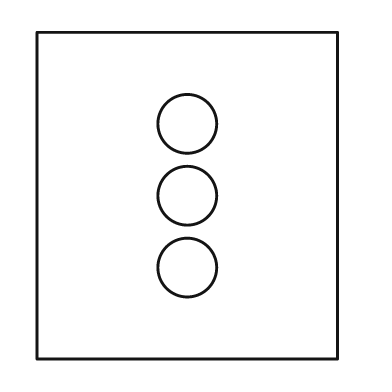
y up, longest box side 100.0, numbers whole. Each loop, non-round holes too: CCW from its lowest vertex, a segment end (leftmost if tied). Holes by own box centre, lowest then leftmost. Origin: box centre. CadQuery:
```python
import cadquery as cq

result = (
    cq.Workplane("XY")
    .moveTo(-46.0, -50.0)
    .lineTo(46.0, -50.0)
    .lineTo(46.0, 50.0)
    .lineTo(-46.0, 50.0)
    .close()
    .moveTo(0.0, -22.0)
    .circle(9.0)
    .moveTo(0.0, 0.0)
    .circle(9.0)
    .moveTo(0.0, 22.0)
    .circle(9.0)
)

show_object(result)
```